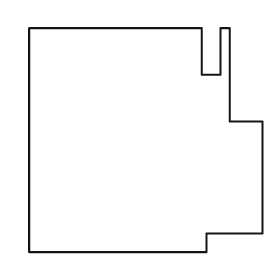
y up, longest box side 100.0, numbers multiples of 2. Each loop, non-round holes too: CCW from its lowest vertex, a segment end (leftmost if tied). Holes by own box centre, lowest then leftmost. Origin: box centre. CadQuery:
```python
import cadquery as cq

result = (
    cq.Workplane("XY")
    .moveTo(-50.0, -48.0)
    .lineTo(26.0, -48.0)
    .lineTo(26.0, -40.0)
    .lineTo(50.0, -40.0)
    .lineTo(50.0, 8.0)
    .lineTo(36.0, 8.0)
    .lineTo(36.0, 48.0)
    .lineTo(32.0, 48.0)
    .lineTo(32.0, 28.0)
    .lineTo(24.0, 28.0)
    .lineTo(24.0, 48.0)
    .lineTo(-50.0, 48.0)
    .close()
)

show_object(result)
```